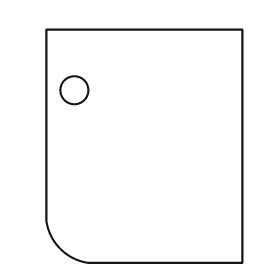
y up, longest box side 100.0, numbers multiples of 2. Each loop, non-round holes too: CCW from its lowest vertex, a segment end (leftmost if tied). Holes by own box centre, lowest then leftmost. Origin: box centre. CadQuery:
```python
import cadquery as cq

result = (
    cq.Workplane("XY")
    .moveTo(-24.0, -50.0)
    .lineTo(42.0, -50.0)
    .lineTo(42.0, 50.0)
    .lineTo(-42.0, 50.0)
    .lineTo(-42.0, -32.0)
    .threePointArc((-36.0, -44.0), (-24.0, -50.0))
    .close()
    .moveTo(-30.0, 24.0)
    .circle(6.0)
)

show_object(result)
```